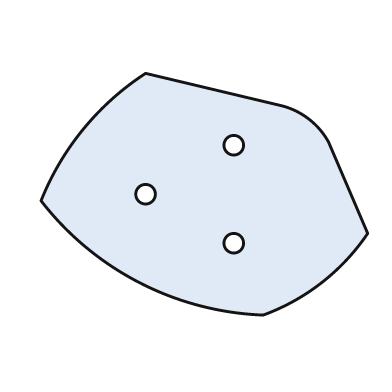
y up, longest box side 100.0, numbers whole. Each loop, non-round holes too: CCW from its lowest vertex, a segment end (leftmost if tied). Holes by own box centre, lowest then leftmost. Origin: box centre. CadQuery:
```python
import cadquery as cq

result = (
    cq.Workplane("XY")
    .moveTo(18.0, -37.0)
    .threePointArc((36.0, -27.0), (50.0, -12.0))
    .lineTo(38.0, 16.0)
    .threePointArc((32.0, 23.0), (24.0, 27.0))
    .lineTo(-18.0, 37.0)
    .threePointArc((-37.0, 20.0), (-50.0, -2.0))
    .threePointArc((-20.0, -27.0), (18.0, -37.0))
    .close()
    .moveTo(9.0, -15.0)
    .circle(3.0)
    .moveTo(-18.0, 0.0)
    .circle(3.0)
    .moveTo(9.0, 15.0)
    .circle(3.0)
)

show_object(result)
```